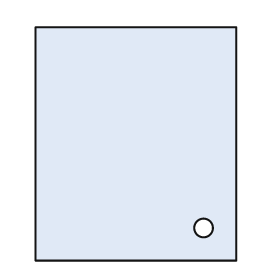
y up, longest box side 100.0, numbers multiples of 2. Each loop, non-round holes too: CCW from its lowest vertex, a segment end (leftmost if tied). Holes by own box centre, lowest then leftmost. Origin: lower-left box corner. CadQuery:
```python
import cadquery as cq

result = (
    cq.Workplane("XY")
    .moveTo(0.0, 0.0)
    .lineTo(86.0, 0.0)
    .lineTo(86.0, 100.0)
    .lineTo(0.0, 100.0)
    .close()
    .moveTo(72.0, 14.0)
    .circle(4.0)
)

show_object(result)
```